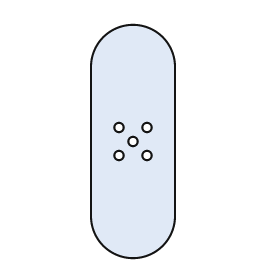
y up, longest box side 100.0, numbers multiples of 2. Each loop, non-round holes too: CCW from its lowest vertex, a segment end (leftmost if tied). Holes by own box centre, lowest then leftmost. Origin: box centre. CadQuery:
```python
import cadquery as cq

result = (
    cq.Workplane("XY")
    .moveTo(-18.0, -32.0)
    .threePointArc((0.0, -50.0), (18.0, -32.0))
    .lineTo(18.0, 32.0)
    .threePointArc((0.0, 50.0), (-18.0, 32.0))
    .close()
    .moveTo(-6.0, -6.0)
    .circle(2.0)
    .moveTo(6.0, -6.0)
    .circle(2.0)
    .moveTo(0.0, 0.0)
    .circle(2.0)
    .moveTo(-6.0, 6.0)
    .circle(2.0)
    .moveTo(6.0, 6.0)
    .circle(2.0)
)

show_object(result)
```